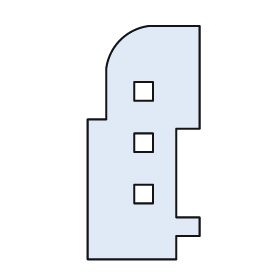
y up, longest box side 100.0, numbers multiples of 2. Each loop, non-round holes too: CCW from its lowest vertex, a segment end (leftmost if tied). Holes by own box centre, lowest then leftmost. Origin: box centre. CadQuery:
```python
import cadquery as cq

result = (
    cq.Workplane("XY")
    .moveTo(-24.0, -50.0)
    .lineTo(14.0, -50.0)
    .lineTo(14.0, -40.0)
    .lineTo(24.0, -40.0)
    .lineTo(24.0, -32.0)
    .lineTo(14.0, -32.0)
    .lineTo(14.0, 6.0)
    .lineTo(24.0, 6.0)
    .lineTo(24.0, 50.0)
    .lineTo(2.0, 50.0)
    .threePointArc((-10.0, 44.0), (-16.0, 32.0))
    .lineTo(-16.0, 10.0)
    .lineTo(-24.0, 10.0)
    .close()
    .moveTo(-4.0, -26.0)
    .lineTo(4.0, -26.0)
    .lineTo(4.0, -18.0)
    .lineTo(-4.0, -18.0)
    .close()
    .moveTo(-4.0, -4.0)
    .lineTo(4.0, -4.0)
    .lineTo(4.0, 4.0)
    .lineTo(-4.0, 4.0)
    .close()
    .moveTo(-4.0, 18.0)
    .lineTo(4.0, 18.0)
    .lineTo(4.0, 26.0)
    .lineTo(-4.0, 26.0)
    .close()
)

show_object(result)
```